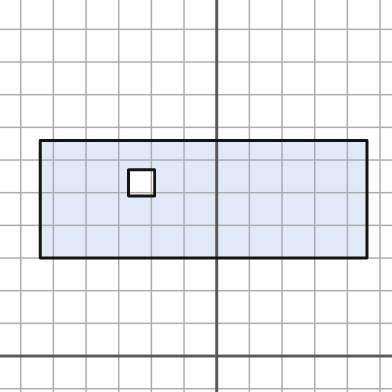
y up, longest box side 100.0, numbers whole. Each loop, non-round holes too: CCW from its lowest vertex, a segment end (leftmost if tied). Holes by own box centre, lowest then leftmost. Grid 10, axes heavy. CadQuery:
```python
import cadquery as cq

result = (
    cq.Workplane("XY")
    .moveTo(-54.0, 30.0)
    .lineTo(46.0, 30.0)
    .lineTo(46.0, 66.0)
    .lineTo(-54.0, 66.0)
    .close()
    .moveTo(-27.0, 49.0)
    .lineTo(-19.0, 49.0)
    .lineTo(-19.0, 57.0)
    .lineTo(-27.0, 57.0)
    .close()
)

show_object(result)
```